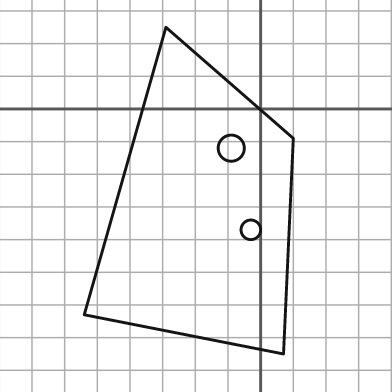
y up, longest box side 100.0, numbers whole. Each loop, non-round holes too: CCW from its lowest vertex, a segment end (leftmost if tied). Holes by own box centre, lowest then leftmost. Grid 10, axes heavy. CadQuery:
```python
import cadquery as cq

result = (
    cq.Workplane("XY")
    .moveTo(7.0, -75.0)
    .lineTo(10.0, -9.0)
    .lineTo(-29.0, 25.0)
    .lineTo(-54.0, -63.0)
    .close()
    .moveTo(-3.0, -37.0)
    .circle(3.0)
    .moveTo(-9.0, -12.0)
    .circle(4.0)
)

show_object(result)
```